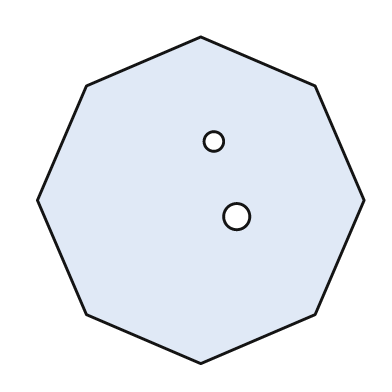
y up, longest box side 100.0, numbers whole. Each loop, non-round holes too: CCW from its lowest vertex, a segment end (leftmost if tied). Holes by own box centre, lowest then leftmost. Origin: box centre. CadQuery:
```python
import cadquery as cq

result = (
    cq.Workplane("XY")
    .moveTo(0.0, -50.0)
    .lineTo(35.0, -35.0)
    .lineTo(50.0, 0.0)
    .lineTo(35.0, 35.0)
    .lineTo(0.0, 50.0)
    .lineTo(-35.0, 35.0)
    .lineTo(-50.0, 0.0)
    .lineTo(-35.0, -35.0)
    .close()
    .moveTo(11.0, -5.0)
    .circle(4.0)
    .moveTo(4.0, 18.0)
    .circle(3.0)
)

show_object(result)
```